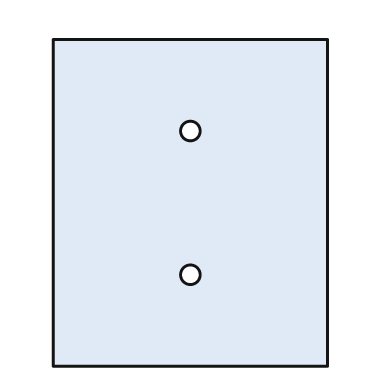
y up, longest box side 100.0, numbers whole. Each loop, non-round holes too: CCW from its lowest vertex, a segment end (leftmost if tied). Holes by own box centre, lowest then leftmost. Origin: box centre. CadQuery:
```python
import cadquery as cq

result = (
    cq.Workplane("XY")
    .moveTo(-42.0, -50.0)
    .lineTo(42.0, -50.0)
    .lineTo(42.0, 50.0)
    .lineTo(-42.0, 50.0)
    .close()
    .moveTo(0.0, -22.0)
    .circle(3.0)
    .moveTo(0.0, 22.0)
    .circle(3.0)
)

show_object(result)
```